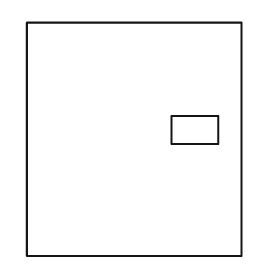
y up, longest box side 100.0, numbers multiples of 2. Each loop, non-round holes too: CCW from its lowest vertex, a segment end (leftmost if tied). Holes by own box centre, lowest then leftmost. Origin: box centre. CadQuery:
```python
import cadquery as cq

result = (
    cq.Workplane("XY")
    .moveTo(-46.0, -50.0)
    .lineTo(46.0, -50.0)
    .lineTo(46.0, 50.0)
    .lineTo(-46.0, 50.0)
    .close()
    .moveTo(16.0, -2.0)
    .lineTo(36.0, -2.0)
    .lineTo(36.0, 10.0)
    .lineTo(16.0, 10.0)
    .close()
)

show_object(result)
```